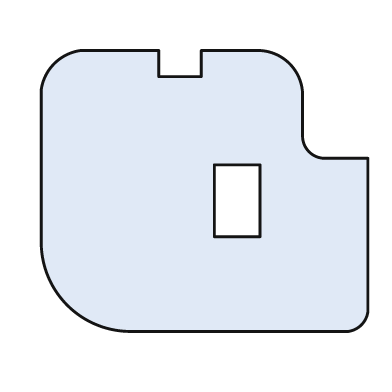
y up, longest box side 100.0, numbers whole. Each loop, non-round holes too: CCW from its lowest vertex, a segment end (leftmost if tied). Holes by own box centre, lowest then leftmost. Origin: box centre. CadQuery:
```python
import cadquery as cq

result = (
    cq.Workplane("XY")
    .moveTo(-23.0, -43.0)
    .lineTo(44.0, -43.0)
    .threePointArc((48.0, -41.0), (50.0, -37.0))
    .lineTo(50.0, 10.0)
    .lineTo(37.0, 10.0)
    .threePointArc((32.0, 12.0), (30.0, 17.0))
    .lineTo(30.0, 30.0)
    .threePointArc((26.0, 39.0), (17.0, 43.0))
    .lineTo(-1.0, 43.0)
    .lineTo(-1.0, 35.0)
    .lineTo(-14.0, 35.0)
    .lineTo(-14.0, 43.0)
    .lineTo(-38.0, 43.0)
    .threePointArc((-46.0, 39.0), (-50.0, 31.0))
    .lineTo(-50.0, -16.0)
    .threePointArc((-42.0, -35.0), (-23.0, -43.0))
    .close()
    .moveTo(3.0, -14.0)
    .lineTo(17.0, -14.0)
    .lineTo(17.0, 8.0)
    .lineTo(3.0, 8.0)
    .close()
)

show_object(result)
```